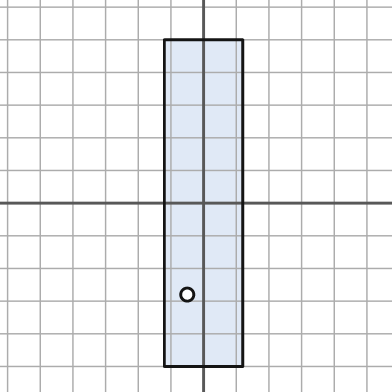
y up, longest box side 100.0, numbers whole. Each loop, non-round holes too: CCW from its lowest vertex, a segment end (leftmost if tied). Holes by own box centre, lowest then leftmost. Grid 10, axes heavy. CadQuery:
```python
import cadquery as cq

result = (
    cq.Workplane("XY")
    .moveTo(-12.0, -50.0)
    .lineTo(12.0, -50.0)
    .lineTo(12.0, 50.0)
    .lineTo(-12.0, 50.0)
    .close()
    .moveTo(-5.0, -28.0)
    .circle(2.0)
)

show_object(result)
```